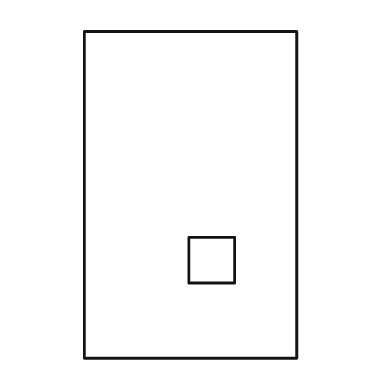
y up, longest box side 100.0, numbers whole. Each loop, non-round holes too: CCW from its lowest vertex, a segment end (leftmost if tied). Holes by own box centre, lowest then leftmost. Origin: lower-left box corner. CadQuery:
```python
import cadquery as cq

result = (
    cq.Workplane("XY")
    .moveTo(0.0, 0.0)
    .lineTo(65.0, 0.0)
    .lineTo(65.0, 100.0)
    .lineTo(0.0, 100.0)
    .close()
    .moveTo(32.0, 23.0)
    .lineTo(46.0, 23.0)
    .lineTo(46.0, 37.0)
    .lineTo(32.0, 37.0)
    .close()
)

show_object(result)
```